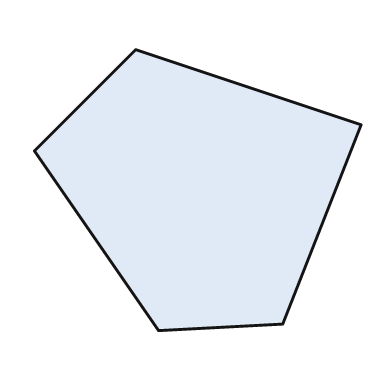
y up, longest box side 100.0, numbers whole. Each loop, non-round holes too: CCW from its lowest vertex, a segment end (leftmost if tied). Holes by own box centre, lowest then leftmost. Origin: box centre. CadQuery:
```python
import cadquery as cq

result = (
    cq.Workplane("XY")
    .moveTo(-12.0, -43.0)
    .lineTo(26.0, -41.0)
    .lineTo(50.0, 20.0)
    .lineTo(-19.0, 43.0)
    .lineTo(-50.0, 12.0)
    .close()
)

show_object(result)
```